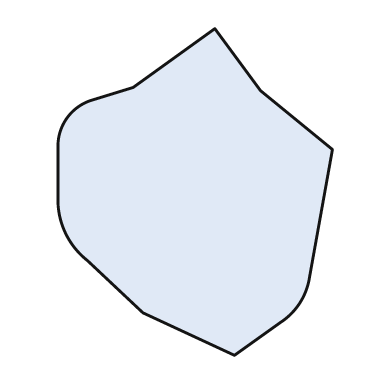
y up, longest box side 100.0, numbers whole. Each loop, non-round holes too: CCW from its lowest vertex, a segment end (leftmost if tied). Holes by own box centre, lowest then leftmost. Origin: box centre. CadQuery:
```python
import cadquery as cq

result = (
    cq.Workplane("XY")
    .moveTo(12.0, -50.0)
    .lineTo(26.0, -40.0)
    .threePointArc((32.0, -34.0), (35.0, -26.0))
    .lineTo(42.0, 13.0)
    .lineTo(20.0, 31.0)
    .lineTo(6.0, 50.0)
    .lineTo(-19.0, 32.0)
    .lineTo(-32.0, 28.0)
    .threePointArc((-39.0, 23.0), (-42.0, 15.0))
    .lineTo(-42.0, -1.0)
    .threePointArc((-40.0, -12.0), (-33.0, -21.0))
    .lineTo(-16.0, -37.0)
    .close()
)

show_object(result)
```